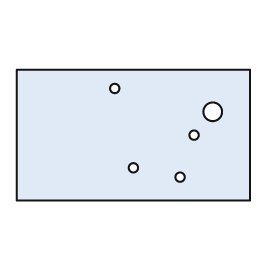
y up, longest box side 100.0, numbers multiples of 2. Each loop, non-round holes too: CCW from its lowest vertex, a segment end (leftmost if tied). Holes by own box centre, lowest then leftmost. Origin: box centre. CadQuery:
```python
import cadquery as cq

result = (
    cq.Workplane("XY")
    .moveTo(-50.0, -28.0)
    .lineTo(50.0, -28.0)
    .lineTo(50.0, 28.0)
    .lineTo(-50.0, 28.0)
    .close()
    .moveTo(20.0, -18.0)
    .circle(2.0)
    .moveTo(0.0, -14.0)
    .circle(2.0)
    .moveTo(26.0, 0.0)
    .circle(2.0)
    .moveTo(34.0, 10.0)
    .circle(4.0)
    .moveTo(-8.0, 20.0)
    .circle(2.0)
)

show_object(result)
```